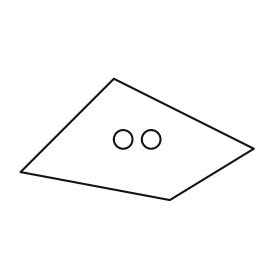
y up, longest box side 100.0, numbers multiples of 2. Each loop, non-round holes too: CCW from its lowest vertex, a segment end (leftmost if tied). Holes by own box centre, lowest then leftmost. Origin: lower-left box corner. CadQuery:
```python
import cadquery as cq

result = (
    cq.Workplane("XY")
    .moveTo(64.0, 0.0)
    .lineTo(100.0, 22.0)
    .lineTo(40.0, 52.0)
    .lineTo(0.0, 12.0)
    .close()
    .moveTo(44.0, 26.0)
    .circle(4.0)
    .moveTo(56.0, 26.0)
    .circle(4.0)
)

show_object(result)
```